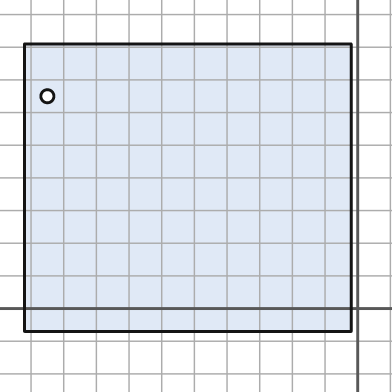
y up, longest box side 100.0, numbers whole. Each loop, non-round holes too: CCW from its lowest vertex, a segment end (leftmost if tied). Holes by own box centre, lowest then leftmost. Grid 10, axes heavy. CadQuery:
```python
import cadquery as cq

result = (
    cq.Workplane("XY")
    .moveTo(-102.0, -7.0)
    .lineTo(-2.0, -7.0)
    .lineTo(-2.0, 81.0)
    .lineTo(-102.0, 81.0)
    .close()
    .moveTo(-95.0, 65.0)
    .circle(2.0)
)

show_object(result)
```